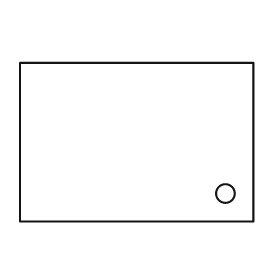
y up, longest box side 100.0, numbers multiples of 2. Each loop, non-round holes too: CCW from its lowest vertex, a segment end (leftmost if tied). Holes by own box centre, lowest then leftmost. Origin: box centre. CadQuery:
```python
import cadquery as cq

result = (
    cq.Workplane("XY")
    .moveTo(-50.0, -34.0)
    .lineTo(50.0, -34.0)
    .lineTo(50.0, 34.0)
    .lineTo(-50.0, 34.0)
    .close()
    .moveTo(38.0, -22.0)
    .circle(4.0)
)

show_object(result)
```